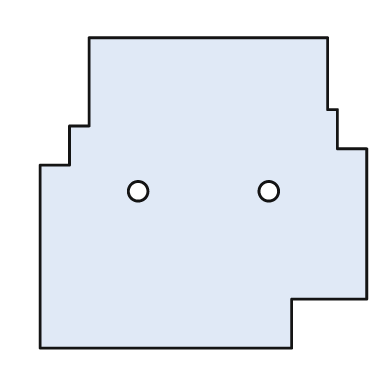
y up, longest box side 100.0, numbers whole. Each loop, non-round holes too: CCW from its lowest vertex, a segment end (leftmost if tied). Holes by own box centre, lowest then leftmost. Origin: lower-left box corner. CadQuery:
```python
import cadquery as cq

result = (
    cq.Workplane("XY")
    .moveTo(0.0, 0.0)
    .lineTo(77.0, 0.0)
    .lineTo(77.0, 15.0)
    .lineTo(100.0, 15.0)
    .lineTo(100.0, 61.0)
    .lineTo(91.0, 61.0)
    .lineTo(91.0, 73.0)
    .lineTo(88.0, 73.0)
    .lineTo(88.0, 95.0)
    .lineTo(15.0, 95.0)
    .lineTo(15.0, 68.0)
    .lineTo(9.0, 68.0)
    .lineTo(9.0, 56.0)
    .lineTo(0.0, 56.0)
    .close()
    .moveTo(30.0, 48.0)
    .circle(3.0)
    .moveTo(70.0, 48.0)
    .circle(3.0)
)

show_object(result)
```